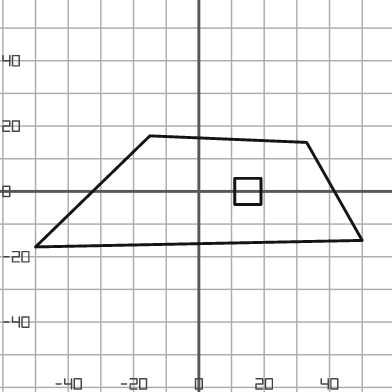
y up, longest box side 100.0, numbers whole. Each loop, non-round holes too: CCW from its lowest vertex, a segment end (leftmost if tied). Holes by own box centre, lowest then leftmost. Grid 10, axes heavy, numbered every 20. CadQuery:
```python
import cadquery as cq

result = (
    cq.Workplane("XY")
    .moveTo(-50.0, -17.0)
    .lineTo(50.0, -15.0)
    .lineTo(33.0, 15.0)
    .lineTo(-15.0, 17.0)
    .close()
    .moveTo(11.0, -4.0)
    .lineTo(19.0, -4.0)
    .lineTo(19.0, 4.0)
    .lineTo(11.0, 4.0)
    .close()
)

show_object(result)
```